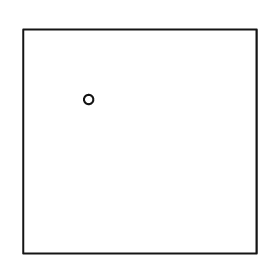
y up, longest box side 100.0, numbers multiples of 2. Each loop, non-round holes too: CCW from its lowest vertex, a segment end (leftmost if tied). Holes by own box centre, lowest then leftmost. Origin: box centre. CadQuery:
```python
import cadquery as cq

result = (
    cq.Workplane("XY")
    .moveTo(-50.0, -48.0)
    .lineTo(50.0, -48.0)
    .lineTo(50.0, 48.0)
    .lineTo(-50.0, 48.0)
    .close()
    .moveTo(-22.0, 18.0)
    .circle(2.0)
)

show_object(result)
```